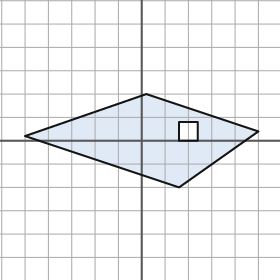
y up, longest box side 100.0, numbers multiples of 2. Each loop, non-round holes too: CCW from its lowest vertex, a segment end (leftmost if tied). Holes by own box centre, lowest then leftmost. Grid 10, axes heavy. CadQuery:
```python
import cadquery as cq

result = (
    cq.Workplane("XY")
    .moveTo(16.0, -20.0)
    .lineTo(50.0, 4.0)
    .lineTo(2.0, 20.0)
    .lineTo(-50.0, 2.0)
    .close()
    .moveTo(16.0, 0.0)
    .lineTo(24.0, 0.0)
    .lineTo(24.0, 8.0)
    .lineTo(16.0, 8.0)
    .close()
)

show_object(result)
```